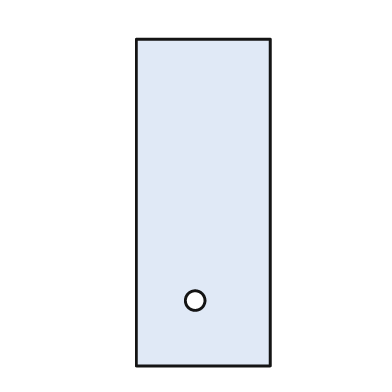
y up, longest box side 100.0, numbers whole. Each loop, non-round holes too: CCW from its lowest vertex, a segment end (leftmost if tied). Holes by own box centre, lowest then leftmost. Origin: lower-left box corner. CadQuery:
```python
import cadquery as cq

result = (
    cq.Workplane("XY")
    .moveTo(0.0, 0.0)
    .lineTo(41.0, 0.0)
    .lineTo(41.0, 100.0)
    .lineTo(0.0, 100.0)
    .close()
    .moveTo(18.0, 20.0)
    .circle(3.0)
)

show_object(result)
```